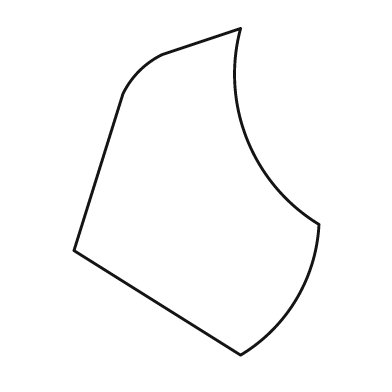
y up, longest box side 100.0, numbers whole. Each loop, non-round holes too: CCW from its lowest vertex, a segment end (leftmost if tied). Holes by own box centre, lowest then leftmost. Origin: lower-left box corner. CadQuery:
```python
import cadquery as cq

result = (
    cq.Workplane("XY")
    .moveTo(51.0, 0.0)
    .threePointArc((68.0, 17.0), (75.0, 40.0))
    .threePointArc((53.0, 66.0), (51.0, 100.0))
    .lineTo(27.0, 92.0)
    .threePointArc((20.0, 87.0), (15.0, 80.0))
    .lineTo(0.0, 32.0)
    .close()
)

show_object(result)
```